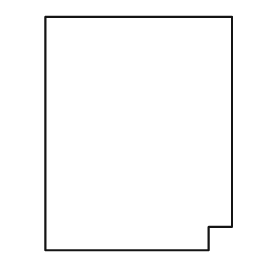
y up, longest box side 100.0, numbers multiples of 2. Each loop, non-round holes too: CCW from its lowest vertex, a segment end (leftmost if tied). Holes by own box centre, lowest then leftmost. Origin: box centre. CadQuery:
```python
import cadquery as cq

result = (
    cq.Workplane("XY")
    .moveTo(-40.0, -50.0)
    .lineTo(30.0, -50.0)
    .lineTo(30.0, -40.0)
    .lineTo(40.0, -40.0)
    .lineTo(40.0, 50.0)
    .lineTo(-40.0, 50.0)
    .close()
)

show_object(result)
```